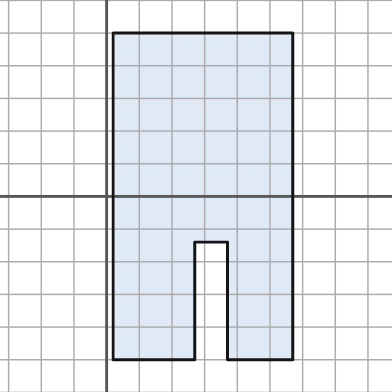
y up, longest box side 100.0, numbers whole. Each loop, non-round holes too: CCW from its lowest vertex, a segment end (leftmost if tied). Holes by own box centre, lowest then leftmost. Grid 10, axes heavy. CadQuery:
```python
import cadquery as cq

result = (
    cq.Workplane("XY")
    .moveTo(2.0, -50.0)
    .lineTo(27.0, -50.0)
    .lineTo(27.0, -14.0)
    .lineTo(37.0, -14.0)
    .lineTo(37.0, -50.0)
    .lineTo(57.0, -50.0)
    .lineTo(57.0, 50.0)
    .lineTo(2.0, 50.0)
    .close()
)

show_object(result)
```